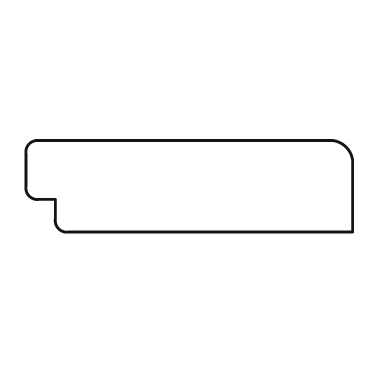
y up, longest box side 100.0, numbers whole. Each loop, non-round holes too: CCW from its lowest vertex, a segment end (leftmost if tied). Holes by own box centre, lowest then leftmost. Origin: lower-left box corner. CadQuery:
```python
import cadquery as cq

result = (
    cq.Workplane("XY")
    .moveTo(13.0, 0.0)
    .lineTo(100.0, 0.0)
    .lineTo(100.0, 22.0)
    .threePointArc((98.0, 26.0), (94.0, 28.0))
    .lineTo(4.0, 28.0)
    .threePointArc((1.0, 27.0), (0.0, 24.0))
    .lineTo(0.0, 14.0)
    .threePointArc((1.0, 11.0), (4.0, 10.0))
    .lineTo(9.0, 10.0)
    .lineTo(9.0, 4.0)
    .threePointArc((10.0, 1.0), (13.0, 0.0))
    .close()
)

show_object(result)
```